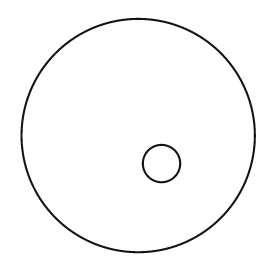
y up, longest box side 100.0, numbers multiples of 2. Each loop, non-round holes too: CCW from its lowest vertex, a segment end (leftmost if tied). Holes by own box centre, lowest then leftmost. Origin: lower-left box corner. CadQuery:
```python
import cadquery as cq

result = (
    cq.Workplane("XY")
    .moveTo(50.0, 50.0)
    .circle(50.0)
    .moveTo(60.0, 38.0)
    .circle(8.0)
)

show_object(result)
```